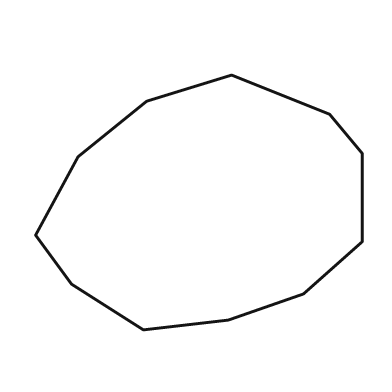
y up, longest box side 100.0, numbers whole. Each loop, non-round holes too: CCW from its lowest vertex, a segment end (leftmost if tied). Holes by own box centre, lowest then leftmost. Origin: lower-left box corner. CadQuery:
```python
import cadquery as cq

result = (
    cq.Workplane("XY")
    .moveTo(33.0, 0.0)
    .lineTo(59.0, 3.0)
    .lineTo(82.0, 11.0)
    .lineTo(100.0, 27.0)
    .lineTo(100.0, 54.0)
    .lineTo(90.0, 66.0)
    .lineTo(60.0, 78.0)
    .lineTo(34.0, 70.0)
    .lineTo(13.0, 53.0)
    .lineTo(0.0, 29.0)
    .lineTo(11.0, 14.0)
    .close()
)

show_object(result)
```